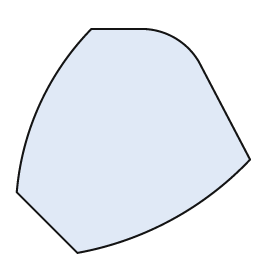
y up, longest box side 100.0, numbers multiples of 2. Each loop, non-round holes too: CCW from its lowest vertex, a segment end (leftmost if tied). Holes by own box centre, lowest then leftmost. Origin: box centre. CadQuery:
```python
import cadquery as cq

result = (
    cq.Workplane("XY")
    .moveTo(-24.0, -48.0)
    .threePointArc((16.0, -34.0), (50.0, -8.0))
    .lineTo(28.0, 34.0)
    .threePointArc((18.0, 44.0), (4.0, 48.0))
    .lineTo(-18.0, 48.0)
    .threePointArc((-40.0, 16.0), (-50.0, -22.0))
    .close()
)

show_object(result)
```